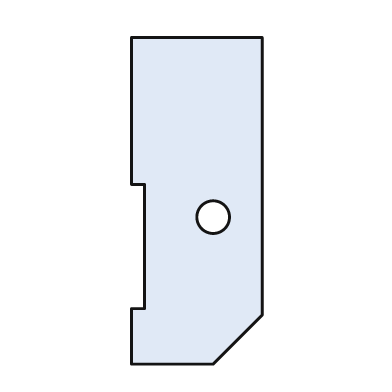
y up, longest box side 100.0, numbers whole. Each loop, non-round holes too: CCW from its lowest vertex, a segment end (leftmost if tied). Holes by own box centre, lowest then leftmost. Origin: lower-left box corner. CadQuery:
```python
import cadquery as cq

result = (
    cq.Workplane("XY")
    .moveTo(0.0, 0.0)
    .lineTo(25.0, 0.0)
    .lineTo(40.0, 15.0)
    .lineTo(40.0, 100.0)
    .lineTo(0.0, 100.0)
    .lineTo(0.0, 55.0)
    .lineTo(4.0, 55.0)
    .lineTo(4.0, 17.0)
    .lineTo(0.0, 17.0)
    .close()
    .moveTo(25.0, 45.0)
    .circle(5.0)
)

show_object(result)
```